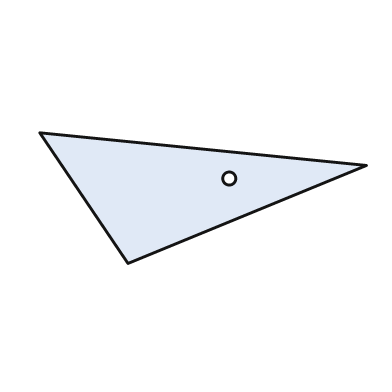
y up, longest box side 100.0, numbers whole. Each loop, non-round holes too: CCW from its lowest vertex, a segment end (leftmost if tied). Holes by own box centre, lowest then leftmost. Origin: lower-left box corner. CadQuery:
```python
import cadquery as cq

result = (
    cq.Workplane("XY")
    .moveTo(27.0, 0.0)
    .lineTo(100.0, 30.0)
    .lineTo(0.0, 40.0)
    .close()
    .moveTo(58.0, 26.0)
    .circle(2.0)
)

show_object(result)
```